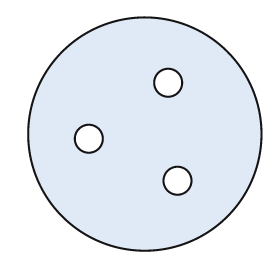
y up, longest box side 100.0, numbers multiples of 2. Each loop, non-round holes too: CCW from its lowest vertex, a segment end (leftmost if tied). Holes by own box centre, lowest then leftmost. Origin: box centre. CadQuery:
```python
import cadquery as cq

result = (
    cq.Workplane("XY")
    .moveTo(0.0, 0.0)
    .circle(50.0)
    .moveTo(14.0, -20.0)
    .circle(6.0)
    .moveTo(-24.0, -2.0)
    .circle(6.0)
    .moveTo(10.0, 22.0)
    .circle(6.0)
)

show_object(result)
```